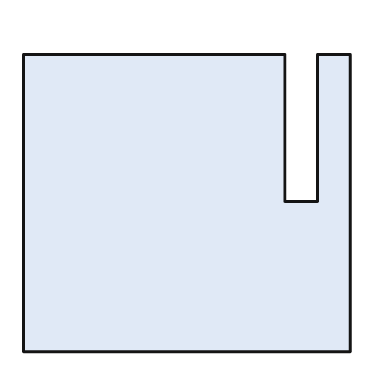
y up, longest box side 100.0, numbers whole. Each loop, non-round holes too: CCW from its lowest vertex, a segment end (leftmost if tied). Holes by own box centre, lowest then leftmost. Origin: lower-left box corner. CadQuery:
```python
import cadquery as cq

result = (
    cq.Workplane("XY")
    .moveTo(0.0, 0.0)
    .lineTo(100.0, 0.0)
    .lineTo(100.0, 91.0)
    .lineTo(90.0, 91.0)
    .lineTo(90.0, 46.0)
    .lineTo(80.0, 46.0)
    .lineTo(80.0, 91.0)
    .lineTo(0.0, 91.0)
    .close()
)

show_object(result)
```